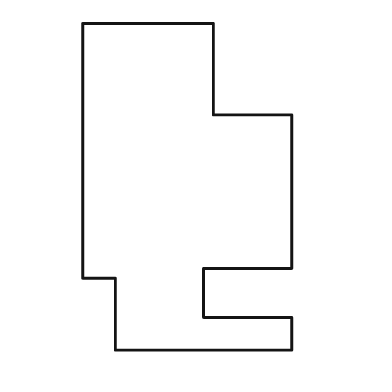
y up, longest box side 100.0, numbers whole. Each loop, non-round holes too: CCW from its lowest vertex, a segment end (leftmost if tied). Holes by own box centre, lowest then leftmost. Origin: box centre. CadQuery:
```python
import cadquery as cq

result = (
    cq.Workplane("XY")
    .moveTo(-22.0, -50.0)
    .lineTo(32.0, -50.0)
    .lineTo(32.0, -40.0)
    .lineTo(5.0, -40.0)
    .lineTo(5.0, -25.0)
    .lineTo(32.0, -25.0)
    .lineTo(32.0, 22.0)
    .lineTo(8.0, 22.0)
    .lineTo(8.0, 50.0)
    .lineTo(-32.0, 50.0)
    .lineTo(-32.0, -28.0)
    .lineTo(-22.0, -28.0)
    .close()
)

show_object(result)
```